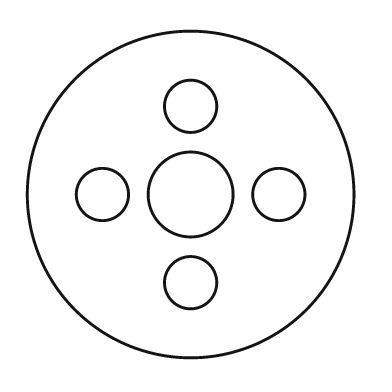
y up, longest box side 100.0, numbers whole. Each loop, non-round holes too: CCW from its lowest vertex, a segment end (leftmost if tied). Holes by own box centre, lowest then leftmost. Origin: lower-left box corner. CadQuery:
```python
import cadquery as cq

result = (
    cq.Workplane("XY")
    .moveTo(50.0, 50.0)
    .circle(50.0)
    .moveTo(50.0, 23.0)
    .circle(8.0)
    .moveTo(23.0, 50.0)
    .circle(8.0)
    .moveTo(50.0, 50.0)
    .circle(13.0)
    .moveTo(77.0, 50.0)
    .circle(8.0)
    .moveTo(50.0, 77.0)
    .circle(8.0)
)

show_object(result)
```